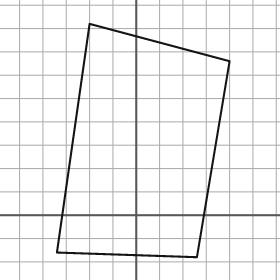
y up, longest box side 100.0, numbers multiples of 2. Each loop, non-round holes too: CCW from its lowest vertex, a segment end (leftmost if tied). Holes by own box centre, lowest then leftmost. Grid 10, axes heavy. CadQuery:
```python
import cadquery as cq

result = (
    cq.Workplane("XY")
    .moveTo(26.0, -18.0)
    .lineTo(40.0, 66.0)
    .lineTo(-20.0, 82.0)
    .lineTo(-34.0, -16.0)
    .close()
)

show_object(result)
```